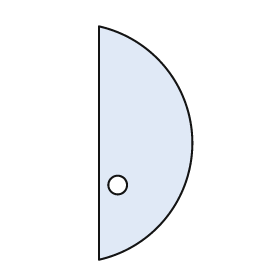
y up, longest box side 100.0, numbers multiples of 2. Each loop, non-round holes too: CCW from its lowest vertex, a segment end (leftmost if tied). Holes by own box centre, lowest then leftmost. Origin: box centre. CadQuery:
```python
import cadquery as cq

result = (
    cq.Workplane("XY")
    .moveTo(-20.0, -50.0)
    .threePointArc((20.0, 0.0), (-20.0, 50.0))
    .close()
    .moveTo(-12.0, -18.0)
    .circle(4.0)
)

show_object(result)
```